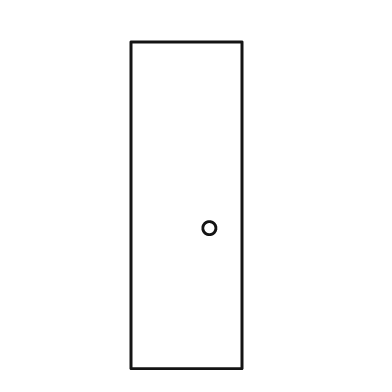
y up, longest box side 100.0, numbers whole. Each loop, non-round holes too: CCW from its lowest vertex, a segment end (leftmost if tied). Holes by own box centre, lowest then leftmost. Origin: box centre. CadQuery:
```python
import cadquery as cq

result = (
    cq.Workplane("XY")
    .moveTo(-17.0, -50.0)
    .lineTo(17.0, -50.0)
    .lineTo(17.0, 50.0)
    .lineTo(-17.0, 50.0)
    .close()
    .moveTo(7.0, -7.0)
    .circle(2.0)
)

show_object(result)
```